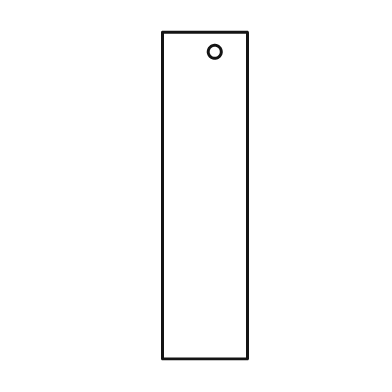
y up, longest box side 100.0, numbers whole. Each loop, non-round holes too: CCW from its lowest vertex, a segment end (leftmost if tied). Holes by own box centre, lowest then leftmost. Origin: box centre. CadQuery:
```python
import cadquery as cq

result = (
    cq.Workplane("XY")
    .moveTo(-13.0, -50.0)
    .lineTo(13.0, -50.0)
    .lineTo(13.0, 50.0)
    .lineTo(-13.0, 50.0)
    .close()
    .moveTo(3.0, 44.0)
    .circle(2.0)
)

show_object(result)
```